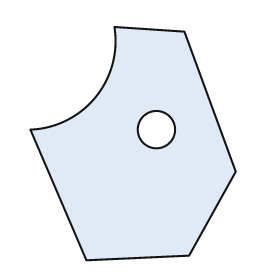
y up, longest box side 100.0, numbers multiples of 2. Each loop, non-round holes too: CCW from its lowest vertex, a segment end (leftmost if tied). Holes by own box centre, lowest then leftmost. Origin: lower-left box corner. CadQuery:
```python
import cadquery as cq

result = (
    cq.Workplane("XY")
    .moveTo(24.0, 0.0)
    .lineTo(68.0, 2.0)
    .lineTo(88.0, 38.0)
    .lineTo(66.0, 98.0)
    .lineTo(36.0, 100.0)
    .threePointArc((28.0, 70.0), (0.0, 56.0))
    .close()
    .moveTo(54.0, 56.0)
    .circle(8.0)
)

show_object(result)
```